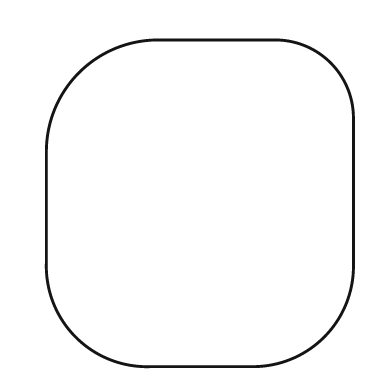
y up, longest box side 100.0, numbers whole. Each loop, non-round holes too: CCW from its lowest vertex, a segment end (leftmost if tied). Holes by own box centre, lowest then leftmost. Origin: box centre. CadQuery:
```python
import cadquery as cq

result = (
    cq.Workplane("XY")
    .moveTo(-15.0, -50.0)
    .lineTo(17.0, -50.0)
    .threePointArc((38.0, -41.0), (47.0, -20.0))
    .lineTo(47.0, 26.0)
    .threePointArc((40.0, 43.0), (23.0, 50.0))
    .lineTo(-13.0, 50.0)
    .threePointArc((-37.0, 40.0), (-47.0, 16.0))
    .lineTo(-47.0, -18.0)
    .threePointArc((-38.0, -41.0), (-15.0, -50.0))
    .close()
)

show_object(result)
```